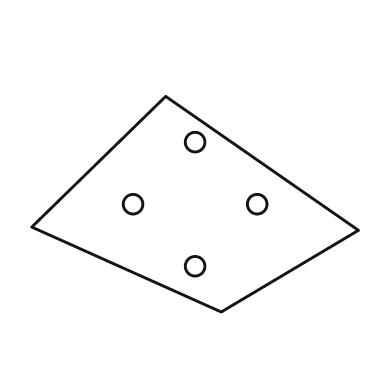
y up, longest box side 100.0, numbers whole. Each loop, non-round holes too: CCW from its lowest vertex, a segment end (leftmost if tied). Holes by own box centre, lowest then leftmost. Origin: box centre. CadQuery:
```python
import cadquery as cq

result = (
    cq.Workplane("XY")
    .moveTo(8.0, -33.0)
    .lineTo(50.0, -8.0)
    .lineTo(-9.0, 33.0)
    .lineTo(-50.0, -7.0)
    .close()
    .moveTo(0.0, -19.0)
    .circle(3.0)
    .moveTo(-19.0, 0.0)
    .circle(3.0)
    .moveTo(19.0, 0.0)
    .circle(3.0)
    .moveTo(0.0, 19.0)
    .circle(3.0)
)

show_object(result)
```